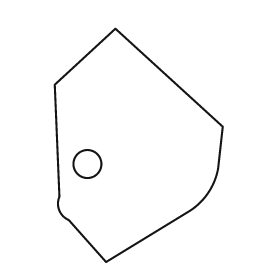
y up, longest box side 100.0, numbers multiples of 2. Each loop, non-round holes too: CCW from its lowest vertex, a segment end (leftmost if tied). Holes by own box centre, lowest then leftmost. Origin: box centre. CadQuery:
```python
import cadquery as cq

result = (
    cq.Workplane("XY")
    .moveTo(-14.0, -50.0)
    .lineTo(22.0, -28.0)
    .threePointArc((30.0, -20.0), (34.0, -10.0))
    .lineTo(36.0, 8.0)
    .lineTo(-10.0, 50.0)
    .lineTo(-36.0, 26.0)
    .lineTo(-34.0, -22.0)
    .threePointArc((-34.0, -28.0), (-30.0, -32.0))
    .close()
    .moveTo(-22.0, -8.0)
    .circle(6.0)
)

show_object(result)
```